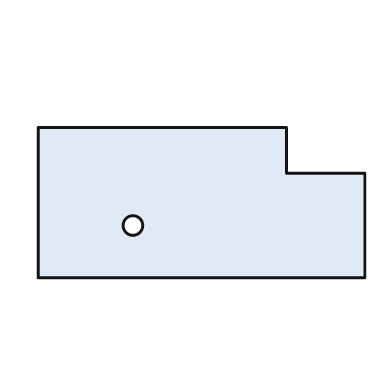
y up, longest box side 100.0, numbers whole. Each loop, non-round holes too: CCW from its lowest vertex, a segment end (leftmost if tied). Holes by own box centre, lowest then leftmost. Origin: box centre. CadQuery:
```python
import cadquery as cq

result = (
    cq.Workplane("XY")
    .moveTo(-50.0, -23.0)
    .lineTo(50.0, -23.0)
    .lineTo(50.0, 9.0)
    .lineTo(26.0, 9.0)
    .lineTo(26.0, 23.0)
    .lineTo(-50.0, 23.0)
    .close()
    .moveTo(-21.0, -7.0)
    .circle(3.0)
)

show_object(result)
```